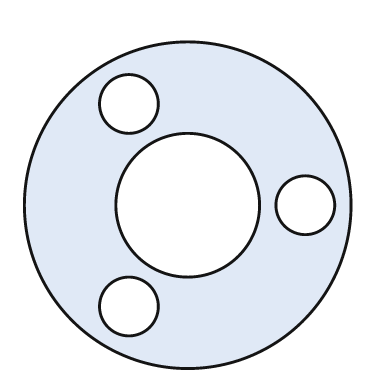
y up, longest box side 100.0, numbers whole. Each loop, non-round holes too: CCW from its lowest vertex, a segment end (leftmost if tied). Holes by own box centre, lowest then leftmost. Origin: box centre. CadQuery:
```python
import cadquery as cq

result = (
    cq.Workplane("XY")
    .moveTo(0.0, 0.0)
    .circle(50.0)
    .moveTo(-18.0, -31.0)
    .circle(9.0)
    .moveTo(0.0, 0.0)
    .circle(22.0)
    .moveTo(36.0, 0.0)
    .circle(9.0)
    .moveTo(-18.0, 31.0)
    .circle(9.0)
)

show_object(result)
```